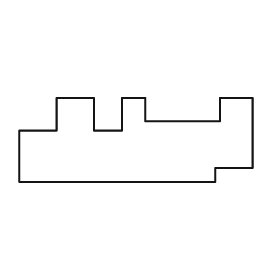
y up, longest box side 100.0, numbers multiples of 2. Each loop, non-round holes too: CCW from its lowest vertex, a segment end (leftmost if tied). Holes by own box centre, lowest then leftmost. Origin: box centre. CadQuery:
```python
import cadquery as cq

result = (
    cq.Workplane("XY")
    .moveTo(-50.0, -18.0)
    .lineTo(34.0, -18.0)
    .lineTo(34.0, -12.0)
    .lineTo(50.0, -12.0)
    .lineTo(50.0, 18.0)
    .lineTo(36.0, 18.0)
    .lineTo(36.0, 8.0)
    .lineTo(4.0, 8.0)
    .lineTo(4.0, 18.0)
    .lineTo(-6.0, 18.0)
    .lineTo(-6.0, 4.0)
    .lineTo(-18.0, 4.0)
    .lineTo(-18.0, 18.0)
    .lineTo(-34.0, 18.0)
    .lineTo(-34.0, 4.0)
    .lineTo(-50.0, 4.0)
    .close()
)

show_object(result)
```